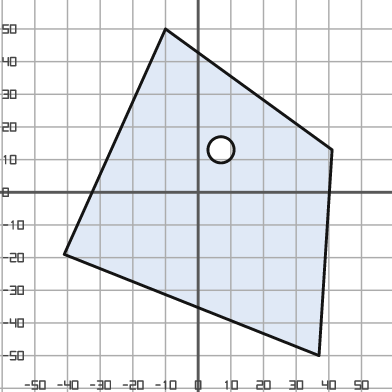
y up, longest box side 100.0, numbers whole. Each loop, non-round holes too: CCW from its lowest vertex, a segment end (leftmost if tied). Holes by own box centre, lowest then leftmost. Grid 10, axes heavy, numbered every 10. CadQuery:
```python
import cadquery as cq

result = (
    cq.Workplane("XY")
    .moveTo(37.0, -50.0)
    .lineTo(41.0, 13.0)
    .lineTo(-10.0, 50.0)
    .lineTo(-41.0, -19.0)
    .close()
    .moveTo(7.0, 13.0)
    .circle(4.0)
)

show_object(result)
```